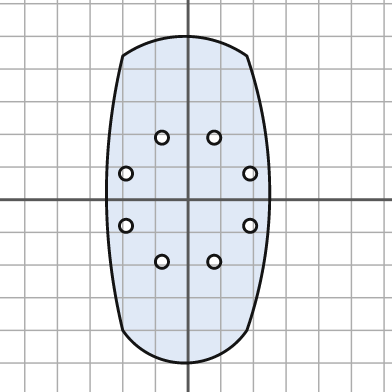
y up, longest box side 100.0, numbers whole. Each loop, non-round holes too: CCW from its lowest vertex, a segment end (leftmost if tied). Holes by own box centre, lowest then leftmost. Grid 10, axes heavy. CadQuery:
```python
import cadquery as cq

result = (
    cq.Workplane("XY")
    .moveTo(-20.0, -40.0)
    .threePointArc((-1.0, -50.0), (18.0, -40.0))
    .threePointArc((25.0, 2.0), (18.0, 44.0))
    .threePointArc((-1.0, 50.0), (-20.0, 44.0))
    .threePointArc((-25.0, 2.0), (-20.0, -40.0))
    .close()
    .moveTo(-8.0, -19.0)
    .circle(2.0)
    .moveTo(8.0, -19.0)
    .circle(2.0)
    .moveTo(-19.0, -8.0)
    .circle(2.0)
    .moveTo(19.0, -8.0)
    .circle(2.0)
    .moveTo(-19.0, 8.0)
    .circle(2.0)
    .moveTo(19.0, 8.0)
    .circle(2.0)
    .moveTo(-8.0, 19.0)
    .circle(2.0)
    .moveTo(8.0, 19.0)
    .circle(2.0)
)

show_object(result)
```